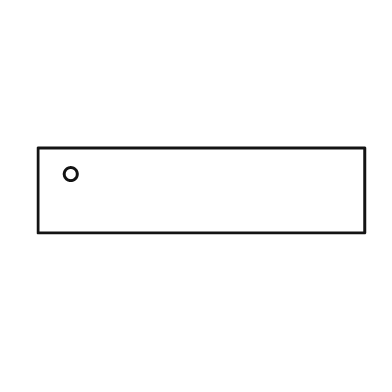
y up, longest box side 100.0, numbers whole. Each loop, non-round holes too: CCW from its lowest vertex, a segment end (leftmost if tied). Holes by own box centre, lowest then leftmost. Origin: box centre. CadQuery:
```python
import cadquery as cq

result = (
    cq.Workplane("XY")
    .moveTo(-50.0, -13.0)
    .lineTo(50.0, -13.0)
    .lineTo(50.0, 13.0)
    .lineTo(-50.0, 13.0)
    .close()
    .moveTo(-40.0, 5.0)
    .circle(2.0)
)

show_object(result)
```